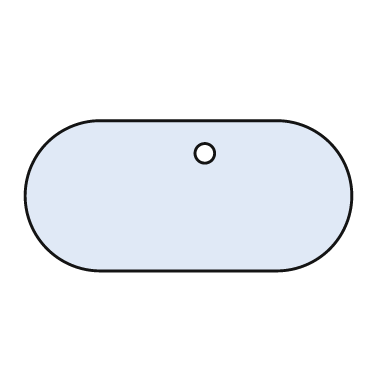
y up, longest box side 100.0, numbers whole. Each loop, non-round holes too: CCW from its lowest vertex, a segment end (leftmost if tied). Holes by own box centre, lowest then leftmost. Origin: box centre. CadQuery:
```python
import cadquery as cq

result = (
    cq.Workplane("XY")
    .moveTo(-27.0, -23.0)
    .lineTo(27.0, -23.0)
    .threePointArc((50.0, 0.0), (27.0, 23.0))
    .lineTo(-27.0, 23.0)
    .threePointArc((-50.0, 0.0), (-27.0, -23.0))
    .close()
    .moveTo(5.0, 13.0)
    .circle(3.0)
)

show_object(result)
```